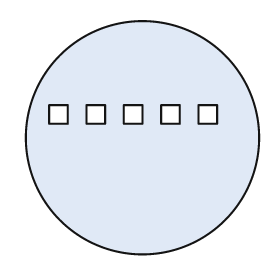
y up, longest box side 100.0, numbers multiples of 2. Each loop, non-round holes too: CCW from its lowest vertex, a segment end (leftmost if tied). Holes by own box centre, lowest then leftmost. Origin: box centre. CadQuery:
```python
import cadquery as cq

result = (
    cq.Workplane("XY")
    .moveTo(0.0, 0.0)
    .circle(50.0)
    .moveTo(-40.0, 6.0)
    .lineTo(-32.0, 6.0)
    .lineTo(-32.0, 14.0)
    .lineTo(-40.0, 14.0)
    .close()
    .moveTo(-24.0, 6.0)
    .lineTo(-16.0, 6.0)
    .lineTo(-16.0, 14.0)
    .lineTo(-24.0, 14.0)
    .close()
    .moveTo(-8.0, 6.0)
    .lineTo(0.0, 6.0)
    .lineTo(0.0, 14.0)
    .lineTo(-8.0, 14.0)
    .close()
    .moveTo(8.0, 6.0)
    .lineTo(16.0, 6.0)
    .lineTo(16.0, 14.0)
    .lineTo(8.0, 14.0)
    .close()
    .moveTo(24.0, 6.0)
    .lineTo(32.0, 6.0)
    .lineTo(32.0, 14.0)
    .lineTo(24.0, 14.0)
    .close()
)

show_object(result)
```